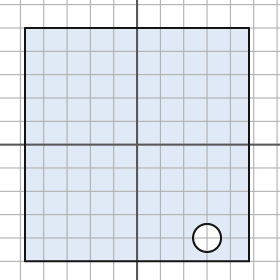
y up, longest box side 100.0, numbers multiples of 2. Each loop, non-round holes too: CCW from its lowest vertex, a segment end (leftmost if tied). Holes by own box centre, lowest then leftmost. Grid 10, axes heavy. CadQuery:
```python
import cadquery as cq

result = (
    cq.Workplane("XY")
    .moveTo(-48.0, -50.0)
    .lineTo(48.0, -50.0)
    .lineTo(48.0, 50.0)
    .lineTo(-48.0, 50.0)
    .close()
    .moveTo(30.0, -40.0)
    .circle(6.0)
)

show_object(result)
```